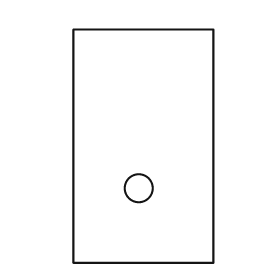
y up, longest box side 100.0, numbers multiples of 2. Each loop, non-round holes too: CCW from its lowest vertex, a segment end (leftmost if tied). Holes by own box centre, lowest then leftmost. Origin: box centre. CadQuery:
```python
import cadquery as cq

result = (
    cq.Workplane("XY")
    .moveTo(-30.0, -50.0)
    .lineTo(30.0, -50.0)
    .lineTo(30.0, 50.0)
    .lineTo(-30.0, 50.0)
    .close()
    .moveTo(-2.0, -18.0)
    .circle(6.0)
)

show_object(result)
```